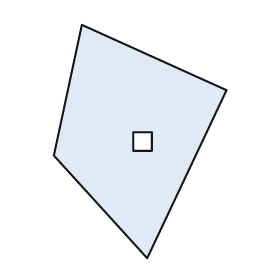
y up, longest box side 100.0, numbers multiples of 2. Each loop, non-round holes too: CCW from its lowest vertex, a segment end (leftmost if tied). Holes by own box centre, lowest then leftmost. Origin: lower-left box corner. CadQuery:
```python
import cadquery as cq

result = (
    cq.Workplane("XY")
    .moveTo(40.0, 0.0)
    .lineTo(74.0, 72.0)
    .lineTo(12.0, 100.0)
    .lineTo(0.0, 44.0)
    .close()
    .moveTo(34.0, 46.0)
    .lineTo(42.0, 46.0)
    .lineTo(42.0, 54.0)
    .lineTo(34.0, 54.0)
    .close()
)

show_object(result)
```